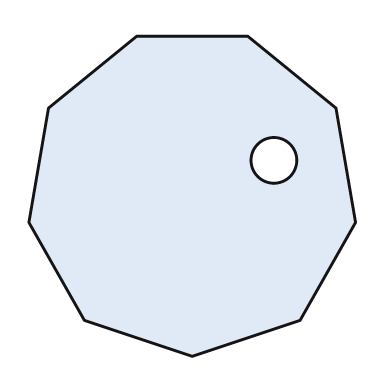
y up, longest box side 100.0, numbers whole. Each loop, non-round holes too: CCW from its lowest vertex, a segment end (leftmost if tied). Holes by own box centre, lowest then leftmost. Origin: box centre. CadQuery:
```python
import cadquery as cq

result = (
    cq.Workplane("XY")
    .moveTo(0.0, -49.0)
    .lineTo(33.0, -38.0)
    .lineTo(50.0, -8.0)
    .lineTo(44.0, 27.0)
    .lineTo(17.0, 49.0)
    .lineTo(-17.0, 49.0)
    .lineTo(-44.0, 27.0)
    .lineTo(-50.0, -8.0)
    .lineTo(-33.0, -38.0)
    .close()
    .moveTo(25.0, 11.0)
    .circle(7.0)
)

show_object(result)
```